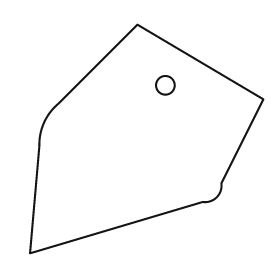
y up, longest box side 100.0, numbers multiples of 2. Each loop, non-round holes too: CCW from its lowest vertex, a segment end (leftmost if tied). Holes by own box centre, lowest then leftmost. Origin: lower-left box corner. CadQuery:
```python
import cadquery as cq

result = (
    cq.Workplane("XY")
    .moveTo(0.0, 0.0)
    .lineTo(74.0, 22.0)
    .threePointArc((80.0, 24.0), (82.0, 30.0))
    .lineTo(100.0, 66.0)
    .lineTo(46.0, 98.0)
    .lineTo(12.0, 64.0)
    .threePointArc((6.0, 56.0), (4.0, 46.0))
    .close()
    .moveTo(58.0, 72.0)
    .circle(4.0)
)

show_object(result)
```